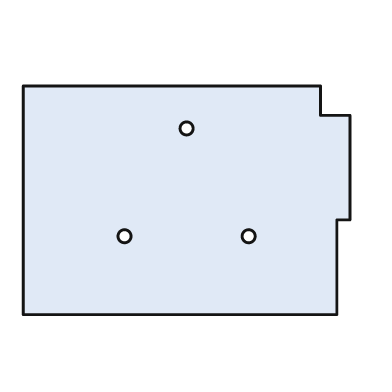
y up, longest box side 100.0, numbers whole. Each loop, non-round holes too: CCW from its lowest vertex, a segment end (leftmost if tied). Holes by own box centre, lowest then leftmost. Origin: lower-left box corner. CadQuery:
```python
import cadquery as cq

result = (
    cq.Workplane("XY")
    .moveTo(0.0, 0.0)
    .lineTo(96.0, 0.0)
    .lineTo(96.0, 29.0)
    .lineTo(100.0, 29.0)
    .lineTo(100.0, 61.0)
    .lineTo(91.0, 61.0)
    .lineTo(91.0, 70.0)
    .lineTo(0.0, 70.0)
    .close()
    .moveTo(31.0, 24.0)
    .circle(2.0)
    .moveTo(69.0, 24.0)
    .circle(2.0)
    .moveTo(50.0, 57.0)
    .circle(2.0)
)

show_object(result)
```